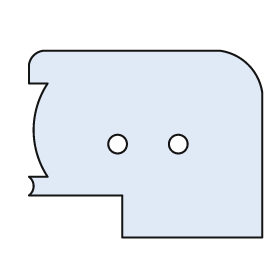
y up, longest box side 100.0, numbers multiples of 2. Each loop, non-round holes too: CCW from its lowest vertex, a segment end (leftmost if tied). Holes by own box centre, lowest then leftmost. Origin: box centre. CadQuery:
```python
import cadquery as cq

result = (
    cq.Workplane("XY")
    .moveTo(-10.0, -40.0)
    .lineTo(50.0, -40.0)
    .lineTo(50.0, 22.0)
    .threePointArc((44.0, 34.0), (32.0, 40.0))
    .lineTo(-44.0, 40.0)
    .threePointArc((-48.0, 38.0), (-50.0, 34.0))
    .lineTo(-50.0, 26.0)
    .lineTo(-42.0, 26.0)
    .threePointArc((-48.0, 6.0), (-42.0, -14.0))
    .lineTo(-50.0, -14.0)
    .threePointArc((-48.0, -18.0), (-50.0, -22.0))
    .lineTo(-10.0, -22.0)
    .close()
    .moveTo(-12.0, 0.0)
    .circle(4.0)
    .moveTo(14.0, 0.0)
    .circle(4.0)
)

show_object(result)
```